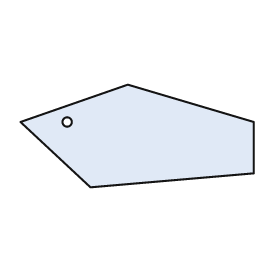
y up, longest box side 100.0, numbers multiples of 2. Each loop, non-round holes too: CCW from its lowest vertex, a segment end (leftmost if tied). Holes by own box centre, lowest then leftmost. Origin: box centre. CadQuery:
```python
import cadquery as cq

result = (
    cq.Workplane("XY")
    .moveTo(-20.0, -22.0)
    .lineTo(50.0, -16.0)
    .lineTo(50.0, 6.0)
    .lineTo(-4.0, 22.0)
    .lineTo(-50.0, 6.0)
    .close()
    .moveTo(-30.0, 6.0)
    .circle(2.0)
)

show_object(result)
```